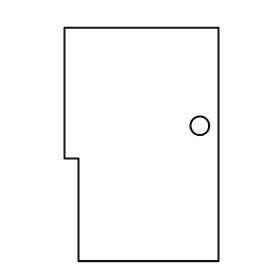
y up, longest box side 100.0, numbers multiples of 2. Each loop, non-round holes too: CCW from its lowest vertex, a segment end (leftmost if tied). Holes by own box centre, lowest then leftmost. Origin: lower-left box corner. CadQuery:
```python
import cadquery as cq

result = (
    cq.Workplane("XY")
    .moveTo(6.0, 0.0)
    .lineTo(66.0, 0.0)
    .lineTo(66.0, 100.0)
    .lineTo(0.0, 100.0)
    .lineTo(0.0, 44.0)
    .lineTo(6.0, 44.0)
    .close()
    .moveTo(58.0, 58.0)
    .circle(4.0)
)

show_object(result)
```